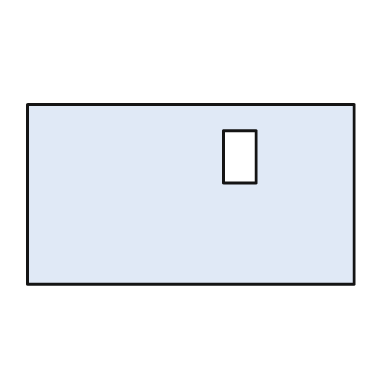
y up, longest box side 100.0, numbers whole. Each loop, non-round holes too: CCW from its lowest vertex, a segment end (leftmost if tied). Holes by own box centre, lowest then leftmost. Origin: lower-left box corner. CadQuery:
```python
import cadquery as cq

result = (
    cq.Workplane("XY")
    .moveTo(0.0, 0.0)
    .lineTo(100.0, 0.0)
    .lineTo(100.0, 55.0)
    .lineTo(0.0, 55.0)
    .close()
    .moveTo(60.0, 31.0)
    .lineTo(70.0, 31.0)
    .lineTo(70.0, 47.0)
    .lineTo(60.0, 47.0)
    .close()
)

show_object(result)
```